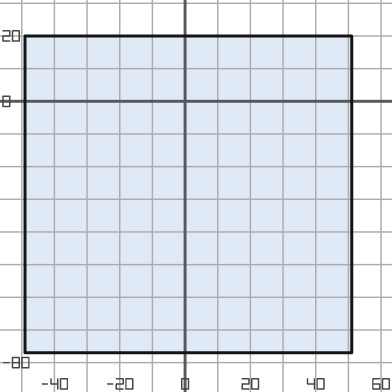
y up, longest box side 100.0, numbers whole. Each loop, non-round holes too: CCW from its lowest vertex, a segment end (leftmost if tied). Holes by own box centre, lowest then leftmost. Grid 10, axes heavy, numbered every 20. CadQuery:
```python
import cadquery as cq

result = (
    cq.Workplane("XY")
    .moveTo(-49.0, -77.0)
    .lineTo(51.0, -77.0)
    .lineTo(51.0, 20.0)
    .lineTo(-49.0, 20.0)
    .close()
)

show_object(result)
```